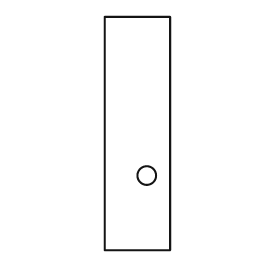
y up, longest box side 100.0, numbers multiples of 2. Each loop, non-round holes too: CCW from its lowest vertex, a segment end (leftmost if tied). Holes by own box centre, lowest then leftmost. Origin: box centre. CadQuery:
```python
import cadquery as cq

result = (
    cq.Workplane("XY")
    .moveTo(-14.0, -50.0)
    .lineTo(14.0, -50.0)
    .lineTo(14.0, 50.0)
    .lineTo(-14.0, 50.0)
    .close()
    .moveTo(4.0, -18.0)
    .circle(4.0)
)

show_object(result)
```